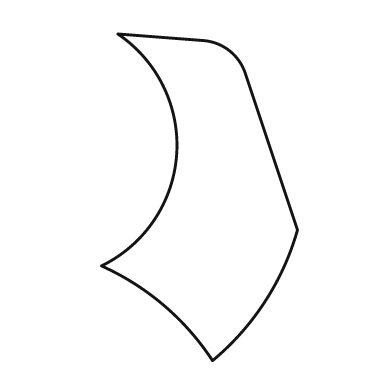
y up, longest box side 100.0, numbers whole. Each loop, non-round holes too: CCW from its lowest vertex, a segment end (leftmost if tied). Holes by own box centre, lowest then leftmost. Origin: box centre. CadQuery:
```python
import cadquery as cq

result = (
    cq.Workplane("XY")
    .moveTo(4.0, -50.0)
    .threePointArc((20.0, -32.0), (30.0, -10.0))
    .lineTo(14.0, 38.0)
    .threePointArc((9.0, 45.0), (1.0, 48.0))
    .lineTo(-25.0, 50.0)
    .threePointArc((-7.0, 13.0), (-30.0, -21.0))
    .threePointArc((-11.0, -33.0), (4.0, -50.0))
    .close()
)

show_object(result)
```